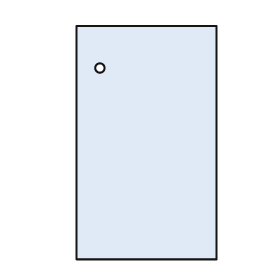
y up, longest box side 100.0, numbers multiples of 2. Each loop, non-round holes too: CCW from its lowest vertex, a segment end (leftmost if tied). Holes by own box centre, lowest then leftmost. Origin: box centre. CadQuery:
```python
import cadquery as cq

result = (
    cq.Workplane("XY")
    .moveTo(-30.0, -50.0)
    .lineTo(30.0, -50.0)
    .lineTo(30.0, 50.0)
    .lineTo(-30.0, 50.0)
    .close()
    .moveTo(-20.0, 32.0)
    .circle(2.0)
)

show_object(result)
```